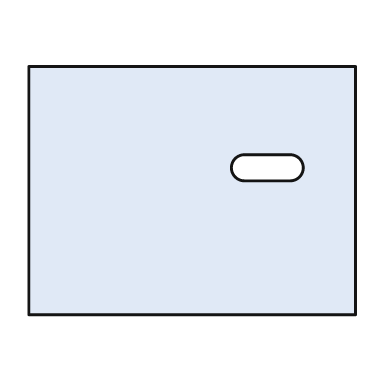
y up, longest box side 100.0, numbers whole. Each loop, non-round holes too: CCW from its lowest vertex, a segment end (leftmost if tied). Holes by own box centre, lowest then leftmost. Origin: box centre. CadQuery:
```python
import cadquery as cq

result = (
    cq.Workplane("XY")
    .moveTo(-50.0, -38.0)
    .lineTo(50.0, -38.0)
    .lineTo(50.0, 38.0)
    .lineTo(-50.0, 38.0)
    .close()
    .moveTo(16.0, 3.0)
    .lineTo(30.0, 3.0)
    .threePointArc((34.0, 7.0), (30.0, 11.0))
    .lineTo(16.0, 11.0)
    .threePointArc((12.0, 7.0), (16.0, 3.0))
    .close()
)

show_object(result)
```